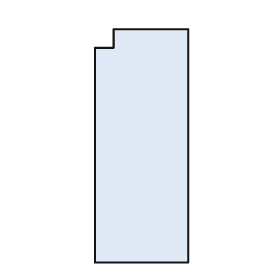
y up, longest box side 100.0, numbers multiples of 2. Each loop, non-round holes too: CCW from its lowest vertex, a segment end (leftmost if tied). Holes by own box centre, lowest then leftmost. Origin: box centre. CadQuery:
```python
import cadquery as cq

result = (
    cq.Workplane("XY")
    .moveTo(-20.0, -50.0)
    .lineTo(20.0, -50.0)
    .lineTo(20.0, 50.0)
    .lineTo(-12.0, 50.0)
    .lineTo(-12.0, 42.0)
    .lineTo(-20.0, 42.0)
    .close()
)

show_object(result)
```